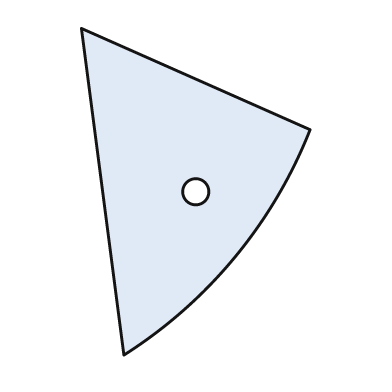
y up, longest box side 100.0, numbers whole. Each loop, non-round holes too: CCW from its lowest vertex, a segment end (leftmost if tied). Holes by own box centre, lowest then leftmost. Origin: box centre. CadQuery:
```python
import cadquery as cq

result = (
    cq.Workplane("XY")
    .moveTo(-22.0, -50.0)
    .threePointArc((12.0, -20.0), (35.0, 19.0))
    .lineTo(-35.0, 50.0)
    .close()
    .moveTo(0.0, 0.0)
    .circle(4.0)
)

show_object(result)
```